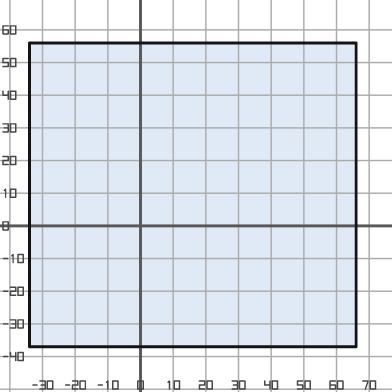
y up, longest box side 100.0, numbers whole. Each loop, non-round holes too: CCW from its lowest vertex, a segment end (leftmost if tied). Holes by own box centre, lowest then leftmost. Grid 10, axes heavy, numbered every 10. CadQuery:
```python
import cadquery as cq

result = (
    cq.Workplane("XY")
    .moveTo(-34.0, -37.0)
    .lineTo(66.0, -37.0)
    .lineTo(66.0, 56.0)
    .lineTo(-34.0, 56.0)
    .close()
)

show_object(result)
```